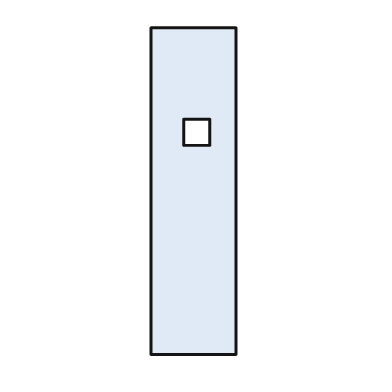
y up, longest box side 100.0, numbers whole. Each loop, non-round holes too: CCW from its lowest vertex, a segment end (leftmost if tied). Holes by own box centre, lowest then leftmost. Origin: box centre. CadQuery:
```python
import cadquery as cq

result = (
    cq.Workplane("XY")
    .moveTo(-13.0, -50.0)
    .lineTo(13.0, -50.0)
    .lineTo(13.0, 50.0)
    .lineTo(-13.0, 50.0)
    .close()
    .moveTo(-3.0, 14.0)
    .lineTo(5.0, 14.0)
    .lineTo(5.0, 22.0)
    .lineTo(-3.0, 22.0)
    .close()
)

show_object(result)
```